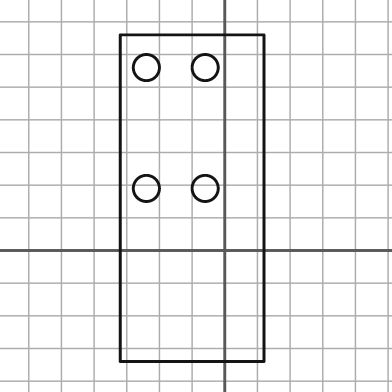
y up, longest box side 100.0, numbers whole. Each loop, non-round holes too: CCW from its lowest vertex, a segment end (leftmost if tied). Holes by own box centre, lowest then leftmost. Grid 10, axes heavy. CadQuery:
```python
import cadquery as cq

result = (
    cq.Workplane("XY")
    .moveTo(-32.0, -34.0)
    .lineTo(12.0, -34.0)
    .lineTo(12.0, 66.0)
    .lineTo(-32.0, 66.0)
    .close()
    .moveTo(-24.0, 19.0)
    .circle(4.0)
    .moveTo(-6.0, 19.0)
    .circle(4.0)
    .moveTo(-24.0, 56.0)
    .circle(4.0)
    .moveTo(-6.0, 56.0)
    .circle(4.0)
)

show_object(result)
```